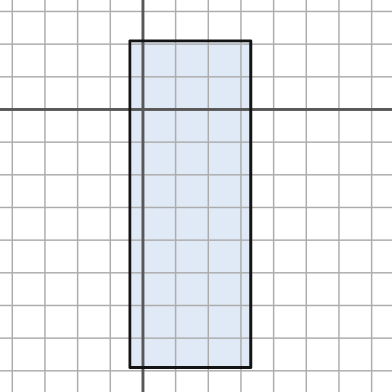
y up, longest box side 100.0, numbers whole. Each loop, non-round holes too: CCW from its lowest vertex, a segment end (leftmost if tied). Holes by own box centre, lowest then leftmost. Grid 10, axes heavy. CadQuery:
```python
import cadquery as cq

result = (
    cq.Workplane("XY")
    .moveTo(-4.0, -79.0)
    .lineTo(33.0, -79.0)
    .lineTo(33.0, 21.0)
    .lineTo(-4.0, 21.0)
    .close()
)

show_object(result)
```